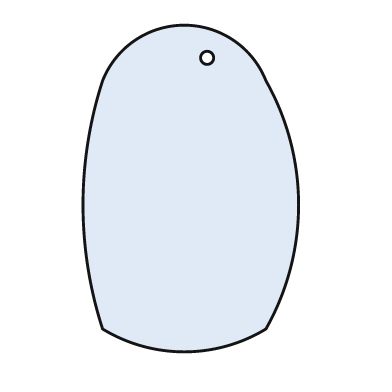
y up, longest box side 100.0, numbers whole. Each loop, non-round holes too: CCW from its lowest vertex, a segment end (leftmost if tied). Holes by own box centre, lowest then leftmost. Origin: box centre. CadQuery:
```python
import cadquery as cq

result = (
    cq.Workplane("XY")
    .moveTo(-27.0, -43.0)
    .threePointArc((-2.0, -50.0), (23.0, -43.0))
    .threePointArc((33.0, -5.0), (23.0, 33.0))
    .threePointArc((-2.0, 50.0), (-27.0, 33.0))
    .threePointArc((-33.0, -5.0), (-27.0, -43.0))
    .close()
    .moveTo(5.0, 40.0)
    .circle(2.0)
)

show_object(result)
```